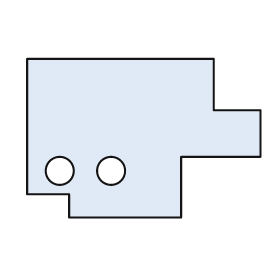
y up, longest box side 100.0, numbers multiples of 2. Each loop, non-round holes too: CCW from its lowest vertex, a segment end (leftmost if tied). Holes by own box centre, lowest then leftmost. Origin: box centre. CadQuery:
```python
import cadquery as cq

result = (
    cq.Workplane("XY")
    .moveTo(-32.0, -34.0)
    .lineTo(16.0, -34.0)
    .lineTo(16.0, -8.0)
    .lineTo(50.0, -8.0)
    .lineTo(50.0, 12.0)
    .lineTo(30.0, 12.0)
    .lineTo(30.0, 34.0)
    .lineTo(-50.0, 34.0)
    .lineTo(-50.0, -24.0)
    .lineTo(-32.0, -24.0)
    .close()
    .moveTo(-36.0, -14.0)
    .circle(6.0)
    .moveTo(-14.0, -14.0)
    .circle(6.0)
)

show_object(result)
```